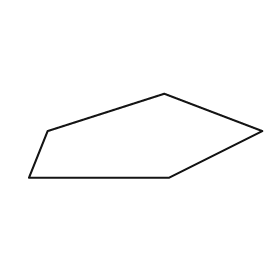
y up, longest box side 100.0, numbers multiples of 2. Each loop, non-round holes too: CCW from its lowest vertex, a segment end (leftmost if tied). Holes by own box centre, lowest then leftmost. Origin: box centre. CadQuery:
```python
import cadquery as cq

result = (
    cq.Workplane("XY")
    .moveTo(-50.0, -18.0)
    .lineTo(10.0, -18.0)
    .lineTo(50.0, 2.0)
    .lineTo(8.0, 18.0)
    .lineTo(-42.0, 2.0)
    .close()
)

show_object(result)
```